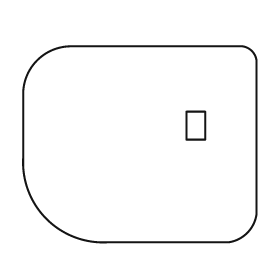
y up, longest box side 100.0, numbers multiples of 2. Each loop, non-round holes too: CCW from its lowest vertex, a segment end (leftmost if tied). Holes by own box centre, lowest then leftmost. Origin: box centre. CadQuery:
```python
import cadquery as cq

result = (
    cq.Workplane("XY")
    .moveTo(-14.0, -42.0)
    .lineTo(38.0, -42.0)
    .threePointArc((46.0, -38.0), (50.0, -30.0))
    .lineTo(50.0, 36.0)
    .threePointArc((48.0, 40.0), (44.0, 42.0))
    .lineTo(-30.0, 42.0)
    .threePointArc((-44.0, 36.0), (-50.0, 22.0))
    .lineTo(-50.0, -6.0)
    .threePointArc((-40.0, -32.0), (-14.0, -42.0))
    .close()
    .moveTo(20.0, 2.0)
    .lineTo(28.0, 2.0)
    .lineTo(28.0, 14.0)
    .lineTo(20.0, 14.0)
    .close()
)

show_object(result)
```